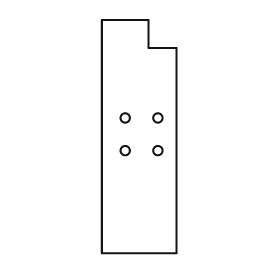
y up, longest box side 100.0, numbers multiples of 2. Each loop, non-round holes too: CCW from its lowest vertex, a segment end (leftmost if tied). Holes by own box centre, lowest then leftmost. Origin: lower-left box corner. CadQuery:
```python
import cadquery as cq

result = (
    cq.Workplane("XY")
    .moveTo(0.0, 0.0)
    .lineTo(32.0, 0.0)
    .lineTo(32.0, 88.0)
    .lineTo(20.0, 88.0)
    .lineTo(20.0, 100.0)
    .lineTo(0.0, 100.0)
    .close()
    .moveTo(10.0, 44.0)
    .circle(2.0)
    .moveTo(24.0, 44.0)
    .circle(2.0)
    .moveTo(10.0, 58.0)
    .circle(2.0)
    .moveTo(24.0, 58.0)
    .circle(2.0)
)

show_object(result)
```